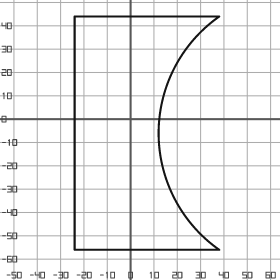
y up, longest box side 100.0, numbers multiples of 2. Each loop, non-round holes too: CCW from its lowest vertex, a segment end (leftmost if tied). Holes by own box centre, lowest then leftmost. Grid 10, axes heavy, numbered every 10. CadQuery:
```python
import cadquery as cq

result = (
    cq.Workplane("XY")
    .moveTo(-24.0, -56.0)
    .lineTo(38.0, -56.0)
    .threePointArc((12.0, -6.0), (38.0, 44.0))
    .lineTo(-24.0, 44.0)
    .close()
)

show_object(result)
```